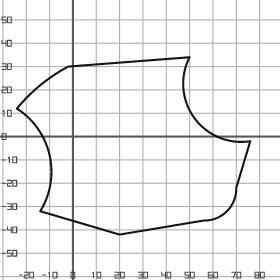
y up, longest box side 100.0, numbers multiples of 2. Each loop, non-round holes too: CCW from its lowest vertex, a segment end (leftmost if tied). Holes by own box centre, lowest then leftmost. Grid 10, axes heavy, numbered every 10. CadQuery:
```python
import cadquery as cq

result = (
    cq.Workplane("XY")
    .moveTo(20.0, -42.0)
    .lineTo(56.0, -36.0)
    .threePointArc((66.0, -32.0), (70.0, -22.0))
    .lineTo(76.0, -2.0)
    .threePointArc((52.0, 8.0), (50.0, 34.0))
    .lineTo(-2.0, 30.0)
    .threePointArc((-14.0, 22.0), (-24.0, 12.0))
    .threePointArc((-10.0, -8.0), (-14.0, -32.0))
    .close()
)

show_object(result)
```